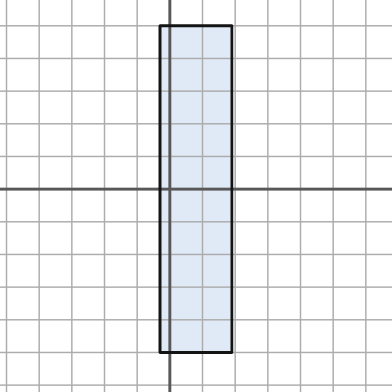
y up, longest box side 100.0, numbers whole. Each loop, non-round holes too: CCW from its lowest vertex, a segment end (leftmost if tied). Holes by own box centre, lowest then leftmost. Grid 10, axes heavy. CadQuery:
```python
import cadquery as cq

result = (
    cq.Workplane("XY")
    .moveTo(-3.0, -50.0)
    .lineTo(19.0, -50.0)
    .lineTo(19.0, 50.0)
    .lineTo(-3.0, 50.0)
    .close()
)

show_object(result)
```